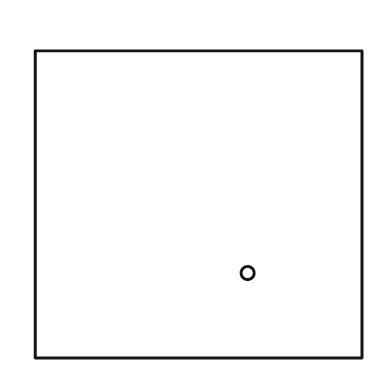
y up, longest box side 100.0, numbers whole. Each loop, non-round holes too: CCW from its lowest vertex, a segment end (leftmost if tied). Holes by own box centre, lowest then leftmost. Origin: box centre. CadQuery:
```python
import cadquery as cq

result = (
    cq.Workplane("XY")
    .moveTo(-50.0, -47.0)
    .lineTo(50.0, -47.0)
    .lineTo(50.0, 47.0)
    .lineTo(-50.0, 47.0)
    .close()
    .moveTo(15.0, -21.0)
    .circle(2.0)
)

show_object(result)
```